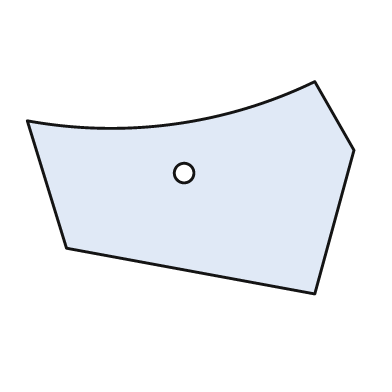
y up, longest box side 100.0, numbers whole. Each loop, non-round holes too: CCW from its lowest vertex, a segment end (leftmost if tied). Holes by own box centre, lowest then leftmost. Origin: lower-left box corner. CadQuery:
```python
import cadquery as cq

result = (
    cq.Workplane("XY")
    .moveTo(88.0, 0.0)
    .lineTo(100.0, 44.0)
    .lineTo(88.0, 65.0)
    .threePointArc((45.0, 52.0), (0.0, 53.0))
    .lineTo(12.0, 14.0)
    .close()
    .moveTo(48.0, 37.0)
    .circle(3.0)
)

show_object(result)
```